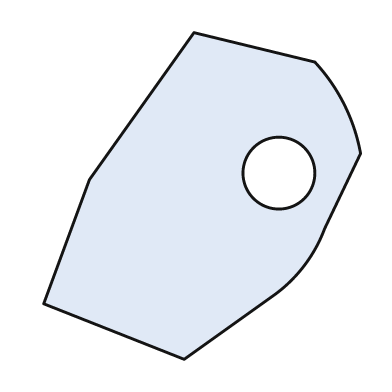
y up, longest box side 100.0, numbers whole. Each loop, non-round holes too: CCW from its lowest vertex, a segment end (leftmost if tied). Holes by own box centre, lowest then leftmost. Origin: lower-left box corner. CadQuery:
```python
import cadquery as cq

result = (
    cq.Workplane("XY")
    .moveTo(43.0, 0.0)
    .lineTo(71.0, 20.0)
    .threePointArc((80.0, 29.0), (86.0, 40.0))
    .lineTo(97.0, 63.0)
    .threePointArc((92.0, 78.0), (83.0, 91.0))
    .lineTo(46.0, 100.0)
    .lineTo(14.0, 55.0)
    .lineTo(0.0, 17.0)
    .close()
    .moveTo(72.0, 57.0)
    .circle(11.0)
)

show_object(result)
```